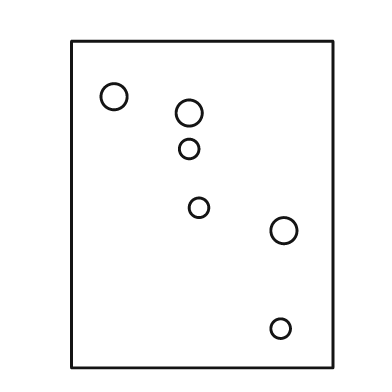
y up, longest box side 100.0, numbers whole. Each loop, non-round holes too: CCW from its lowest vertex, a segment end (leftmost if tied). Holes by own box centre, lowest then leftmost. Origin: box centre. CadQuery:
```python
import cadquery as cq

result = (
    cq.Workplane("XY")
    .moveTo(-40.0, -50.0)
    .lineTo(40.0, -50.0)
    .lineTo(40.0, 50.0)
    .lineTo(-40.0, 50.0)
    .close()
    .moveTo(24.0, -38.0)
    .circle(3.0)
    .moveTo(25.0, -8.0)
    .circle(4.0)
    .moveTo(-1.0, -1.0)
    .circle(3.0)
    .moveTo(-4.0, 17.0)
    .circle(3.0)
    .moveTo(-4.0, 28.0)
    .circle(4.0)
    .moveTo(-27.0, 33.0)
    .circle(4.0)
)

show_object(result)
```